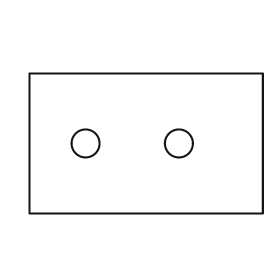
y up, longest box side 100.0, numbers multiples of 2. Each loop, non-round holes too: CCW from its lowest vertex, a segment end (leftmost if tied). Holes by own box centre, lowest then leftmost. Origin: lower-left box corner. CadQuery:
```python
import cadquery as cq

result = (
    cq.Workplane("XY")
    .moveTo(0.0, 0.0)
    .lineTo(100.0, 0.0)
    .lineTo(100.0, 60.0)
    .lineTo(0.0, 60.0)
    .close()
    .moveTo(24.0, 30.0)
    .circle(6.0)
    .moveTo(64.0, 30.0)
    .circle(6.0)
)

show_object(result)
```